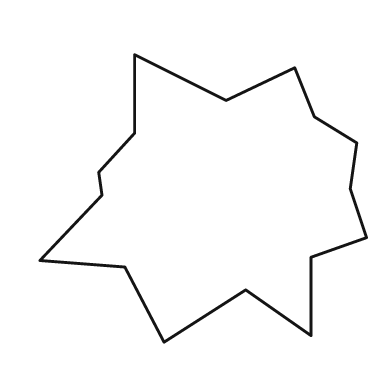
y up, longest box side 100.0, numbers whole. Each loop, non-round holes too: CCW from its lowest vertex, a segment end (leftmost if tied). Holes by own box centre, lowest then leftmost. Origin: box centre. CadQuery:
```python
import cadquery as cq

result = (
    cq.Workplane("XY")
    .moveTo(-12.0, -44.0)
    .lineTo(13.0, -28.0)
    .lineTo(33.0, -42.0)
    .lineTo(33.0, -18.0)
    .lineTo(50.0, -12.0)
    .lineTo(45.0, 3.0)
    .lineTo(47.0, 17.0)
    .lineTo(34.0, 25.0)
    .lineTo(28.0, 40.0)
    .lineTo(7.0, 30.0)
    .lineTo(-21.0, 44.0)
    .lineTo(-21.0, 20.0)
    .lineTo(-32.0, 8.0)
    .lineTo(-31.0, 1.0)
    .lineTo(-50.0, -19.0)
    .lineTo(-24.0, -21.0)
    .close()
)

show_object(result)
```